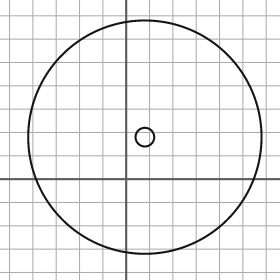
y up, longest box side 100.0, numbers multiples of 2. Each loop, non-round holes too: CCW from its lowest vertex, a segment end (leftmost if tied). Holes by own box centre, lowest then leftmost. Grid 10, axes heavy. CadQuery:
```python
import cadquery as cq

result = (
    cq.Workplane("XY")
    .moveTo(8.0, 18.0)
    .circle(50.0)
    .moveTo(8.0, 18.0)
    .circle(4.0)
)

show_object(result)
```